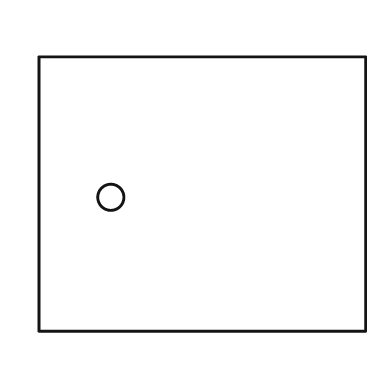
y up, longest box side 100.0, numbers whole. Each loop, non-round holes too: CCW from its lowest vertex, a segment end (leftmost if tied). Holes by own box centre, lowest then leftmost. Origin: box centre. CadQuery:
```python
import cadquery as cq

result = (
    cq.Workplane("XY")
    .moveTo(-50.0, -42.0)
    .lineTo(50.0, -42.0)
    .lineTo(50.0, 42.0)
    .lineTo(-50.0, 42.0)
    .close()
    .moveTo(-28.0, -1.0)
    .circle(4.0)
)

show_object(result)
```